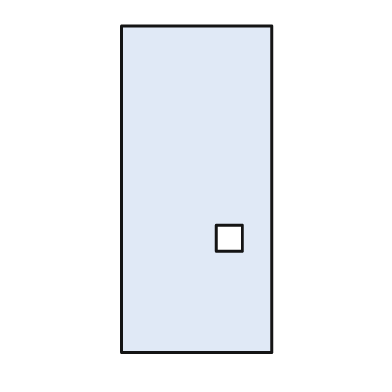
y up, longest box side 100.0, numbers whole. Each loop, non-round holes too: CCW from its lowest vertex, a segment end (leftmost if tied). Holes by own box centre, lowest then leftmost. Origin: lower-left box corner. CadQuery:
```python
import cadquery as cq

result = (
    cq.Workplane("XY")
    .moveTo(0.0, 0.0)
    .lineTo(46.0, 0.0)
    .lineTo(46.0, 100.0)
    .lineTo(0.0, 100.0)
    .close()
    .moveTo(29.0, 31.0)
    .lineTo(37.0, 31.0)
    .lineTo(37.0, 39.0)
    .lineTo(29.0, 39.0)
    .close()
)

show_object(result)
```